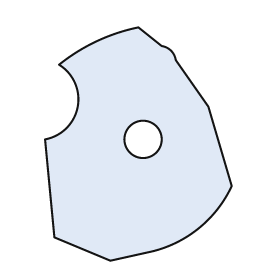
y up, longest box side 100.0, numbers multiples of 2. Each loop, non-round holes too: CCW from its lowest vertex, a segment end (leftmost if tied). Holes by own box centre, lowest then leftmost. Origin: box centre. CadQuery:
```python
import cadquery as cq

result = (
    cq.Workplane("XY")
    .moveTo(-12.0, -50.0)
    .lineTo(6.0, -46.0)
    .threePointArc((26.0, -36.0), (40.0, -18.0))
    .lineTo(30.0, 16.0)
    .lineTo(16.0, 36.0)
    .threePointArc((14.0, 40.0), (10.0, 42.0))
    .lineTo(0.0, 50.0)
    .threePointArc((-18.0, 44.0), (-34.0, 34.0))
    .threePointArc((-26.0, 16.0), (-40.0, 2.0))
    .lineTo(-36.0, -40.0)
    .close()
    .moveTo(2.0, 2.0)
    .circle(8.0)
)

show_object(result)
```